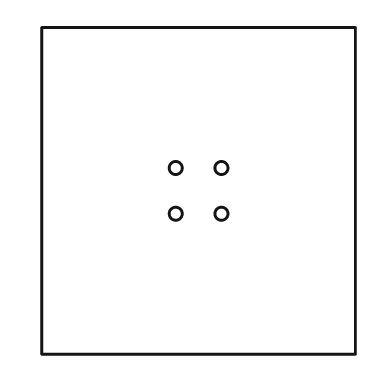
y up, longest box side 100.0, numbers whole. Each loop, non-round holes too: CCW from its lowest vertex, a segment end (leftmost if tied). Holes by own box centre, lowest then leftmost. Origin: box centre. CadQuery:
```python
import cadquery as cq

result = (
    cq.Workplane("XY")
    .moveTo(-48.0, -50.0)
    .lineTo(48.0, -50.0)
    .lineTo(48.0, 50.0)
    .lineTo(-48.0, 50.0)
    .close()
    .moveTo(-7.0, -7.0)
    .circle(2.0)
    .moveTo(7.0, -7.0)
    .circle(2.0)
    .moveTo(-7.0, 7.0)
    .circle(2.0)
    .moveTo(7.0, 7.0)
    .circle(2.0)
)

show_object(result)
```